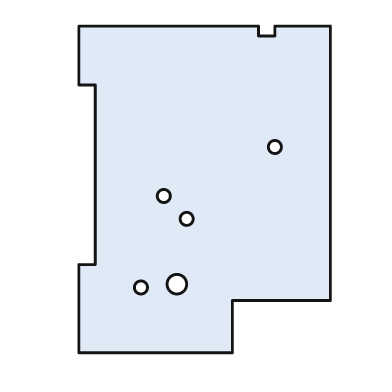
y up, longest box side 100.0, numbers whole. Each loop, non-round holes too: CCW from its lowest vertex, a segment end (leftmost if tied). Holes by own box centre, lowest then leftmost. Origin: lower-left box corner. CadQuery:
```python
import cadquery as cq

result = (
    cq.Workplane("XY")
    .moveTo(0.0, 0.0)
    .lineTo(47.0, 0.0)
    .lineTo(47.0, 16.0)
    .lineTo(77.0, 16.0)
    .lineTo(77.0, 100.0)
    .lineTo(60.0, 100.0)
    .lineTo(60.0, 97.0)
    .lineTo(55.0, 97.0)
    .lineTo(55.0, 100.0)
    .lineTo(0.0, 100.0)
    .lineTo(0.0, 82.0)
    .lineTo(5.0, 82.0)
    .lineTo(5.0, 27.0)
    .lineTo(0.0, 27.0)
    .close()
    .moveTo(19.0, 20.0)
    .circle(2.0)
    .moveTo(30.0, 21.0)
    .circle(3.0)
    .moveTo(33.0, 41.0)
    .circle(2.0)
    .moveTo(26.0, 48.0)
    .circle(2.0)
    .moveTo(60.0, 63.0)
    .circle(2.0)
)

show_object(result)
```